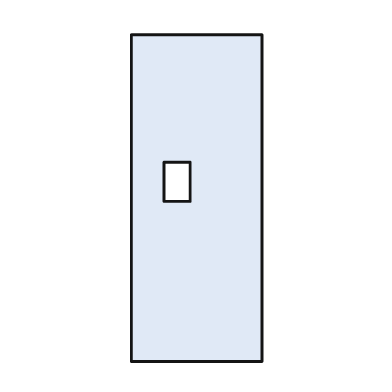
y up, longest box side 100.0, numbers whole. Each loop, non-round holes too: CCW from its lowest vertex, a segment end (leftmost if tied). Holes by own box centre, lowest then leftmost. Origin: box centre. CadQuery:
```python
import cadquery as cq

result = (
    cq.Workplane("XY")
    .moveTo(-20.0, -50.0)
    .lineTo(20.0, -50.0)
    .lineTo(20.0, 50.0)
    .lineTo(-20.0, 50.0)
    .close()
    .moveTo(-10.0, -1.0)
    .lineTo(-2.0, -1.0)
    .lineTo(-2.0, 11.0)
    .lineTo(-10.0, 11.0)
    .close()
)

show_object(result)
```